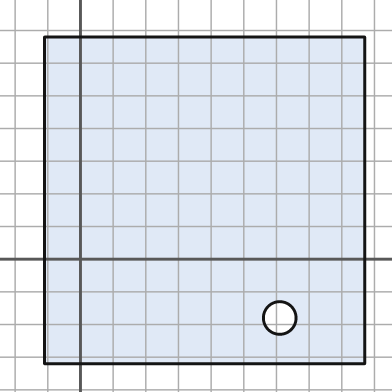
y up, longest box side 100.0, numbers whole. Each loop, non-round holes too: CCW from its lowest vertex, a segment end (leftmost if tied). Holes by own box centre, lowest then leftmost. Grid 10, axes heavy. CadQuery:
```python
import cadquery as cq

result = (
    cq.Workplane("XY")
    .moveTo(-11.0, -32.0)
    .lineTo(87.0, -32.0)
    .lineTo(87.0, 68.0)
    .lineTo(-11.0, 68.0)
    .close()
    .moveTo(61.0, -18.0)
    .circle(5.0)
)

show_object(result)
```